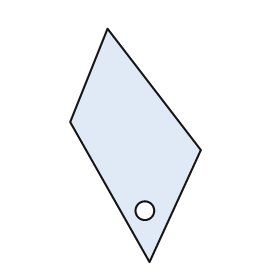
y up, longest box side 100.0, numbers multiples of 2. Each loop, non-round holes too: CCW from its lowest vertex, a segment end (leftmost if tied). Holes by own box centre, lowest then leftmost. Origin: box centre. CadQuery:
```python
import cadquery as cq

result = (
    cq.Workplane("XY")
    .moveTo(6.0, -50.0)
    .lineTo(28.0, -2.0)
    .lineTo(-12.0, 50.0)
    .lineTo(-28.0, 10.0)
    .close()
    .moveTo(4.0, -28.0)
    .circle(4.0)
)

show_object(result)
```